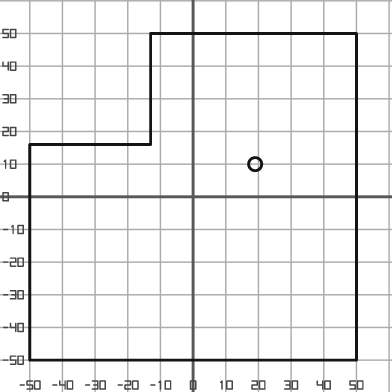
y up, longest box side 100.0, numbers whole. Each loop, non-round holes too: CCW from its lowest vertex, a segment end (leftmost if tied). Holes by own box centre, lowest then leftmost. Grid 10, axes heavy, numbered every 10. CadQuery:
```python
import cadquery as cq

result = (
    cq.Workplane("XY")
    .moveTo(-50.0, -50.0)
    .lineTo(50.0, -50.0)
    .lineTo(50.0, 50.0)
    .lineTo(-13.0, 50.0)
    .lineTo(-13.0, 16.0)
    .lineTo(-50.0, 16.0)
    .close()
    .moveTo(19.0, 10.0)
    .circle(2.0)
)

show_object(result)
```